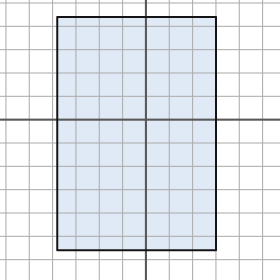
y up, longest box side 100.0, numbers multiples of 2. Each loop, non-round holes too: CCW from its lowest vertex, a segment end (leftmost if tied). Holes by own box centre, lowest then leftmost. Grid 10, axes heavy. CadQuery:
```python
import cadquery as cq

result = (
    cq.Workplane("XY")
    .moveTo(-38.0, -56.0)
    .lineTo(30.0, -56.0)
    .lineTo(30.0, 44.0)
    .lineTo(-38.0, 44.0)
    .close()
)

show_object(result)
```